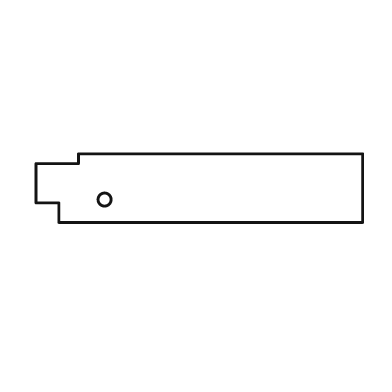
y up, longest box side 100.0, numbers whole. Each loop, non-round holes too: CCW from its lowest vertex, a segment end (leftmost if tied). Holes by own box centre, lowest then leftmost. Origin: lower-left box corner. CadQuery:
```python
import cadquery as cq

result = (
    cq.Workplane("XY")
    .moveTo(7.0, 0.0)
    .lineTo(100.0, 0.0)
    .lineTo(100.0, 21.0)
    .lineTo(13.0, 21.0)
    .lineTo(13.0, 18.0)
    .lineTo(0.0, 18.0)
    .lineTo(0.0, 6.0)
    .lineTo(7.0, 6.0)
    .close()
    .moveTo(21.0, 7.0)
    .circle(2.0)
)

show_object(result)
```